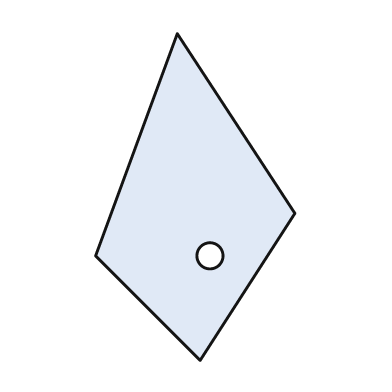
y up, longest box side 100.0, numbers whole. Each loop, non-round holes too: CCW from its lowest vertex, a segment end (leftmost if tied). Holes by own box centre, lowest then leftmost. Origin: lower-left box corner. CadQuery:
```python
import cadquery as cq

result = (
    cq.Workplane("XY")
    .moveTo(32.0, 0.0)
    .lineTo(61.0, 45.0)
    .lineTo(25.0, 100.0)
    .lineTo(0.0, 32.0)
    .close()
    .moveTo(35.0, 32.0)
    .circle(4.0)
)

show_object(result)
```